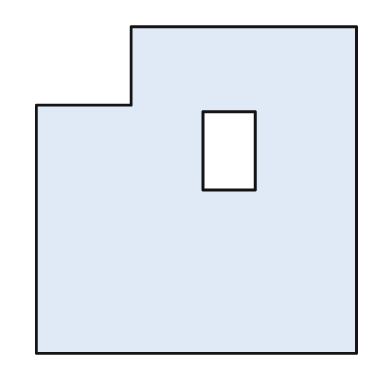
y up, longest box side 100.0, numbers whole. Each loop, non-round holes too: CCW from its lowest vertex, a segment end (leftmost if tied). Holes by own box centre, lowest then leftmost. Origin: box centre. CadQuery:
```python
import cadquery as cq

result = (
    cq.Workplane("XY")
    .moveTo(-49.0, -50.0)
    .lineTo(49.0, -50.0)
    .lineTo(49.0, 50.0)
    .lineTo(-20.0, 50.0)
    .lineTo(-20.0, 26.0)
    .lineTo(-49.0, 26.0)
    .close()
    .moveTo(2.0, 0.0)
    .lineTo(18.0, 0.0)
    .lineTo(18.0, 24.0)
    .lineTo(2.0, 24.0)
    .close()
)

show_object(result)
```